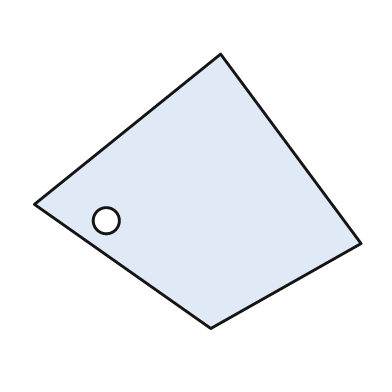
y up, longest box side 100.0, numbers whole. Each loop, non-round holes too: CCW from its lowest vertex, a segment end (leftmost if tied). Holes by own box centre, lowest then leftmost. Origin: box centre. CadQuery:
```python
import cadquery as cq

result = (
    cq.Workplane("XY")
    .moveTo(4.0, -42.0)
    .lineTo(50.0, -16.0)
    .lineTo(7.0, 42.0)
    .lineTo(-50.0, -4.0)
    .close()
    .moveTo(-28.0, -9.0)
    .circle(4.0)
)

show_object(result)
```